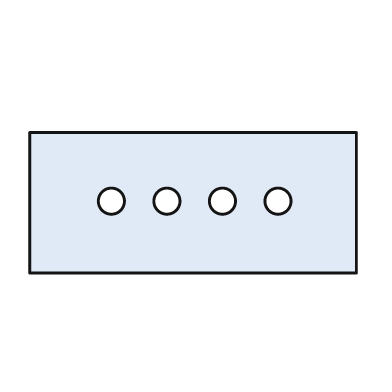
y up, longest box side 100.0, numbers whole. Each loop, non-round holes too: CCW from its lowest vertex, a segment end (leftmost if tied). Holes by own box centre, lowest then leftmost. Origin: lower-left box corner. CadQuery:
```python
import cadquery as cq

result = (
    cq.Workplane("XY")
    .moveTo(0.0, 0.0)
    .lineTo(100.0, 0.0)
    .lineTo(100.0, 43.0)
    .lineTo(0.0, 43.0)
    .close()
    .moveTo(25.0, 22.0)
    .circle(4.0)
    .moveTo(42.0, 22.0)
    .circle(4.0)
    .moveTo(59.0, 22.0)
    .circle(4.0)
    .moveTo(76.0, 22.0)
    .circle(4.0)
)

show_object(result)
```